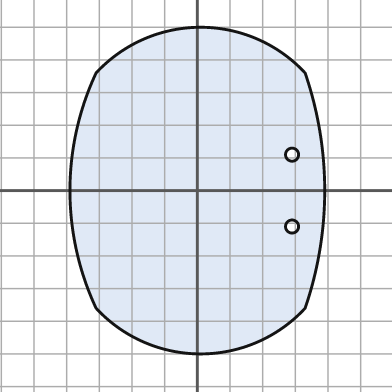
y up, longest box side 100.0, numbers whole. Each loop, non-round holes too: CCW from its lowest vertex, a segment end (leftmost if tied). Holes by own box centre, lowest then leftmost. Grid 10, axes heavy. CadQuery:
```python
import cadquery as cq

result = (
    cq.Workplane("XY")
    .moveTo(-31.0, -36.0)
    .threePointArc((1.0, -50.0), (33.0, -36.0))
    .threePointArc((39.0, 0.0), (33.0, 36.0))
    .threePointArc((1.0, 50.0), (-31.0, 36.0))
    .threePointArc((-39.0, 0.0), (-31.0, -36.0))
    .close()
    .moveTo(29.0, -11.0)
    .circle(2.0)
    .moveTo(29.0, 11.0)
    .circle(2.0)
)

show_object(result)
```